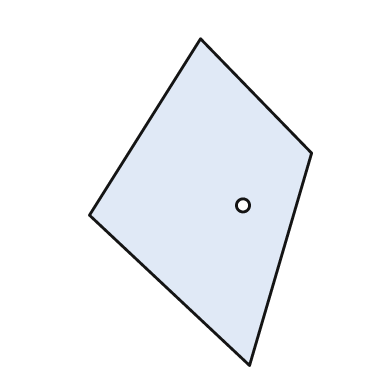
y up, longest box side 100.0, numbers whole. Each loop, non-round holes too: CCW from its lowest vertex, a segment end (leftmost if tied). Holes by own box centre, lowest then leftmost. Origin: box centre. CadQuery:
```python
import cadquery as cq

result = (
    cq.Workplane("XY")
    .moveTo(15.0, -50.0)
    .lineTo(34.0, 15.0)
    .lineTo(0.0, 50.0)
    .lineTo(-34.0, -4.0)
    .close()
    .moveTo(13.0, -1.0)
    .circle(2.0)
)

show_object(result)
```